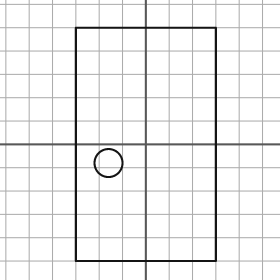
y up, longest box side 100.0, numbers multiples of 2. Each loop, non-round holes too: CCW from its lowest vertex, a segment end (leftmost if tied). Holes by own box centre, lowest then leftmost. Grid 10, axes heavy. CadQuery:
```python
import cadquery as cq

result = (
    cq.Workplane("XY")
    .moveTo(-30.0, -50.0)
    .lineTo(30.0, -50.0)
    .lineTo(30.0, 50.0)
    .lineTo(-30.0, 50.0)
    .close()
    .moveTo(-16.0, -8.0)
    .circle(6.0)
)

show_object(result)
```